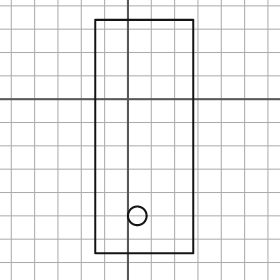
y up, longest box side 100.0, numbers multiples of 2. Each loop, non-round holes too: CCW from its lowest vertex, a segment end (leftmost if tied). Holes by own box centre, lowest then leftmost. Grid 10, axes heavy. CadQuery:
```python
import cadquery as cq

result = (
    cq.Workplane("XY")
    .moveTo(-14.0, -66.0)
    .lineTo(28.0, -66.0)
    .lineTo(28.0, 34.0)
    .lineTo(-14.0, 34.0)
    .close()
    .moveTo(4.0, -50.0)
    .circle(4.0)
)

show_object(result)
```